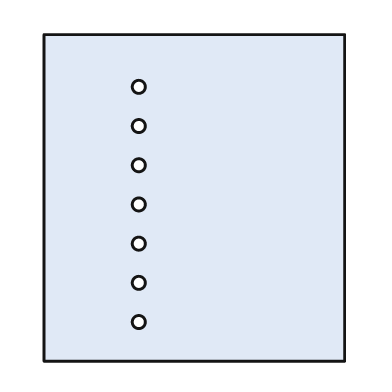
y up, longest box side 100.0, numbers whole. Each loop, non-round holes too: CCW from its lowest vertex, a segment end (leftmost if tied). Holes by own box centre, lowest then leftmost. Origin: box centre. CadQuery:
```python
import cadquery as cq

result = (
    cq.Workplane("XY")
    .moveTo(-46.0, -50.0)
    .lineTo(46.0, -50.0)
    .lineTo(46.0, 50.0)
    .lineTo(-46.0, 50.0)
    .close()
    .moveTo(-17.0, -38.0)
    .circle(2.0)
    .moveTo(-17.0, -26.0)
    .circle(2.0)
    .moveTo(-17.0, -14.0)
    .circle(2.0)
    .moveTo(-17.0, -2.0)
    .circle(2.0)
    .moveTo(-17.0, 10.0)
    .circle(2.0)
    .moveTo(-17.0, 22.0)
    .circle(2.0)
    .moveTo(-17.0, 34.0)
    .circle(2.0)
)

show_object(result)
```